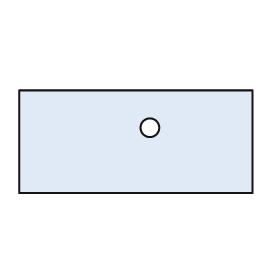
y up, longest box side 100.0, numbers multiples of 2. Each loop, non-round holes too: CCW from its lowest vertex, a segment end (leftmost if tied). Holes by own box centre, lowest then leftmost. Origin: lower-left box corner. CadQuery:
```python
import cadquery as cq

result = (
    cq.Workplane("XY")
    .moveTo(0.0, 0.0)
    .lineTo(100.0, 0.0)
    .lineTo(100.0, 44.0)
    .lineTo(0.0, 44.0)
    .close()
    .moveTo(56.0, 28.0)
    .circle(4.0)
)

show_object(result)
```